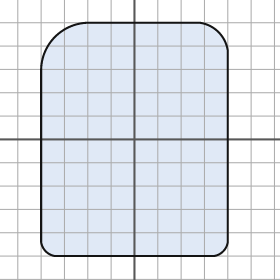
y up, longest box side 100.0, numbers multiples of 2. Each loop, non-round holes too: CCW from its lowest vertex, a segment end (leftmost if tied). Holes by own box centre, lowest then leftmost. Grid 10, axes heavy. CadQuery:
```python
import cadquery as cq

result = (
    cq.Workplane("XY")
    .moveTo(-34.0, -50.0)
    .lineTo(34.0, -50.0)
    .threePointArc((38.0, -48.0), (40.0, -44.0))
    .lineTo(40.0, 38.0)
    .threePointArc((36.0, 46.0), (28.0, 50.0))
    .lineTo(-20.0, 50.0)
    .threePointArc((-34.0, 44.0), (-40.0, 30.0))
    .lineTo(-40.0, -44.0)
    .threePointArc((-38.0, -48.0), (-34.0, -50.0))
    .close()
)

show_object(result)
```